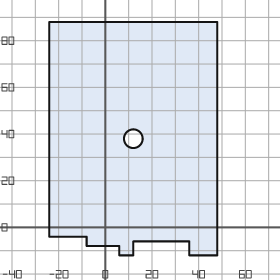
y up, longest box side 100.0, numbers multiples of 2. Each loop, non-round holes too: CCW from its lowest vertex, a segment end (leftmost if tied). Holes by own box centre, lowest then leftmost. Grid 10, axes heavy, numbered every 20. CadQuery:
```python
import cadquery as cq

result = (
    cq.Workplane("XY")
    .moveTo(6.0, -12.0)
    .lineTo(12.0, -12.0)
    .lineTo(12.0, -6.0)
    .lineTo(36.0, -6.0)
    .lineTo(36.0, -12.0)
    .lineTo(48.0, -12.0)
    .lineTo(48.0, 88.0)
    .lineTo(-24.0, 88.0)
    .lineTo(-24.0, -4.0)
    .lineTo(-8.0, -4.0)
    .lineTo(-8.0, -8.0)
    .lineTo(6.0, -8.0)
    .close()
    .moveTo(12.0, 38.0)
    .circle(4.0)
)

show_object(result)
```